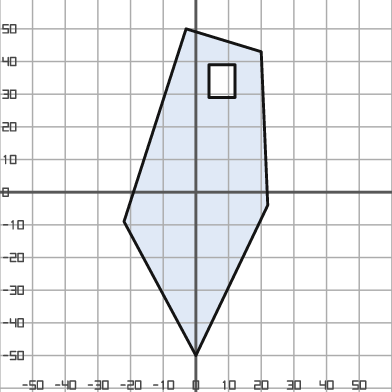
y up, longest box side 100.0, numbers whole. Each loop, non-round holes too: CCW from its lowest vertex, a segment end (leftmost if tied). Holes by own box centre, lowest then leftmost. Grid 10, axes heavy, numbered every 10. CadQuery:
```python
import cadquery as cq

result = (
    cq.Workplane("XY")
    .moveTo(0.0, -50.0)
    .lineTo(22.0, -4.0)
    .lineTo(20.0, 43.0)
    .lineTo(-3.0, 50.0)
    .lineTo(-22.0, -9.0)
    .close()
    .moveTo(4.0, 29.0)
    .lineTo(12.0, 29.0)
    .lineTo(12.0, 39.0)
    .lineTo(4.0, 39.0)
    .close()
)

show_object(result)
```